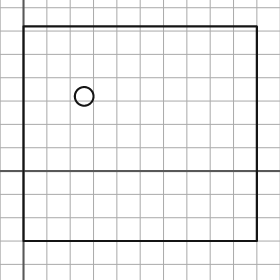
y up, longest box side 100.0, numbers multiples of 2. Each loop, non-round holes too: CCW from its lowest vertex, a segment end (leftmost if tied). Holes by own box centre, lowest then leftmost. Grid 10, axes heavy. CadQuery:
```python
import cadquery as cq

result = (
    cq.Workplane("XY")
    .moveTo(0.0, -30.0)
    .lineTo(100.0, -30.0)
    .lineTo(100.0, 62.0)
    .lineTo(0.0, 62.0)
    .close()
    .moveTo(26.0, 32.0)
    .circle(4.0)
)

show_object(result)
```